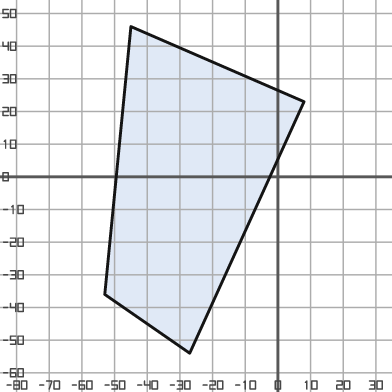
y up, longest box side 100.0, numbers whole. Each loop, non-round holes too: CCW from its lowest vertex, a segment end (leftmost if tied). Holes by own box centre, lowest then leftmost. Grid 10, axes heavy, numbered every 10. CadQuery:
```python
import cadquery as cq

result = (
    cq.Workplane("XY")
    .moveTo(-27.0, -54.0)
    .lineTo(8.0, 23.0)
    .lineTo(-45.0, 46.0)
    .lineTo(-53.0, -36.0)
    .close()
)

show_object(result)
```